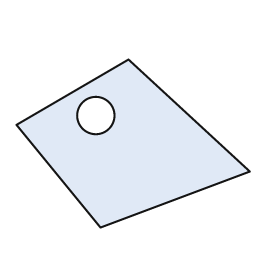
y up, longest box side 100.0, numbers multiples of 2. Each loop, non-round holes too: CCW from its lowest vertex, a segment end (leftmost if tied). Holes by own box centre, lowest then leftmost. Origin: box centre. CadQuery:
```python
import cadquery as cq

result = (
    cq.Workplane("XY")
    .moveTo(-14.0, -36.0)
    .lineTo(50.0, -12.0)
    .lineTo(-2.0, 36.0)
    .lineTo(-50.0, 8.0)
    .close()
    .moveTo(-16.0, 12.0)
    .circle(8.0)
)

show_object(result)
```